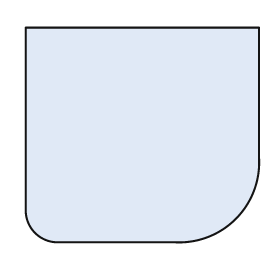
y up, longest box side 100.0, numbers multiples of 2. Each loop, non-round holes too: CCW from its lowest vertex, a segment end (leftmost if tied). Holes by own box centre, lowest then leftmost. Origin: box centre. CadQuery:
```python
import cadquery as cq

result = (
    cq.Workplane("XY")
    .moveTo(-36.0, -46.0)
    .lineTo(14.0, -46.0)
    .threePointArc((40.0, -36.0), (50.0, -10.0))
    .lineTo(50.0, 46.0)
    .lineTo(-50.0, 46.0)
    .lineTo(-50.0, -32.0)
    .threePointArc((-46.0, -42.0), (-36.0, -46.0))
    .close()
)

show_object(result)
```